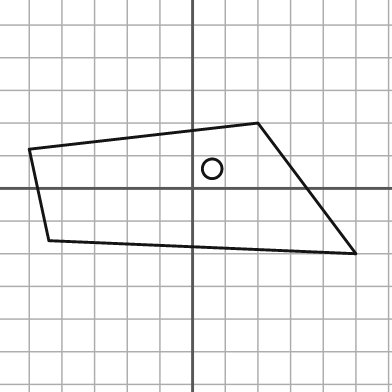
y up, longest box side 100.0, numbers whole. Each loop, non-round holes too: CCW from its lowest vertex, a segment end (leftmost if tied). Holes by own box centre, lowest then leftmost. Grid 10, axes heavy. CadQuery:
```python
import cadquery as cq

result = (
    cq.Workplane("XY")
    .moveTo(50.0, -20.0)
    .lineTo(20.0, 20.0)
    .lineTo(-50.0, 12.0)
    .lineTo(-44.0, -16.0)
    .close()
    .moveTo(6.0, 6.0)
    .circle(3.0)
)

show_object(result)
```